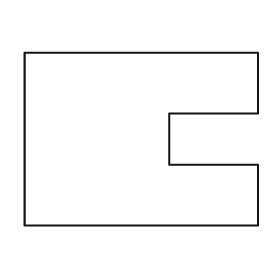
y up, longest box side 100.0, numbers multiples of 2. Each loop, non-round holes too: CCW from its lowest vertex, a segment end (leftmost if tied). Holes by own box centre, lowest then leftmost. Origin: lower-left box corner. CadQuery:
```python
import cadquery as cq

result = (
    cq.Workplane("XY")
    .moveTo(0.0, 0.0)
    .lineTo(100.0, 0.0)
    .lineTo(100.0, 26.0)
    .lineTo(62.0, 26.0)
    .lineTo(62.0, 48.0)
    .lineTo(100.0, 48.0)
    .lineTo(100.0, 74.0)
    .lineTo(0.0, 74.0)
    .close()
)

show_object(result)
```